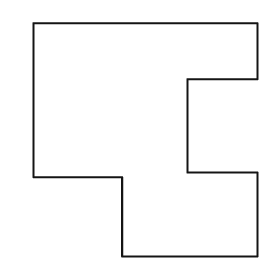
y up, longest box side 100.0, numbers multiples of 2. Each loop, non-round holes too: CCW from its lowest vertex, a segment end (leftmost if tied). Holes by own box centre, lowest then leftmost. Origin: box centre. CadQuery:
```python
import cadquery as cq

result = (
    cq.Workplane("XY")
    .moveTo(-10.0, -50.0)
    .lineTo(48.0, -50.0)
    .lineTo(48.0, -14.0)
    .lineTo(18.0, -14.0)
    .lineTo(18.0, 26.0)
    .lineTo(48.0, 26.0)
    .lineTo(48.0, 50.0)
    .lineTo(-48.0, 50.0)
    .lineTo(-48.0, -16.0)
    .lineTo(-10.0, -16.0)
    .close()
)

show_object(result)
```